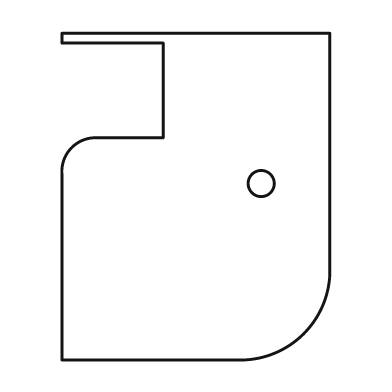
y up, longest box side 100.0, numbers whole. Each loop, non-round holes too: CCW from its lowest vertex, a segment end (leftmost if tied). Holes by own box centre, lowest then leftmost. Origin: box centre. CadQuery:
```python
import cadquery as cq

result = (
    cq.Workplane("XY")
    .moveTo(-41.0, -50.0)
    .lineTo(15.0, -50.0)
    .threePointArc((33.0, -42.0), (41.0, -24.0))
    .lineTo(41.0, 50.0)
    .lineTo(-41.0, 50.0)
    .lineTo(-41.0, 47.0)
    .lineTo(-10.0, 47.0)
    .lineTo(-10.0, 18.0)
    .lineTo(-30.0, 18.0)
    .threePointArc((-38.0, 15.0), (-41.0, 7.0))
    .close()
    .moveTo(20.0, 4.0)
    .circle(4.0)
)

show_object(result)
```